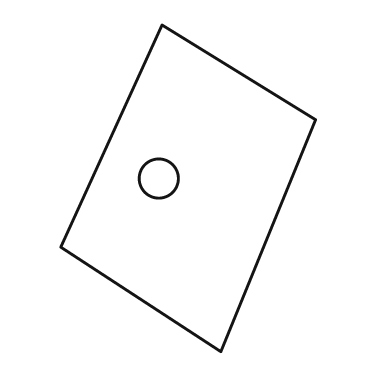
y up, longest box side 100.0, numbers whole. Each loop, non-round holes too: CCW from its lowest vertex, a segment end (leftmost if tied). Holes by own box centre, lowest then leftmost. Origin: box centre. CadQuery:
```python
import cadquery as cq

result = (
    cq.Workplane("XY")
    .moveTo(10.0, -50.0)
    .lineTo(39.0, 21.0)
    .lineTo(-8.0, 50.0)
    .lineTo(-39.0, -18.0)
    .close()
    .moveTo(-9.0, 3.0)
    .circle(6.0)
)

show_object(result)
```